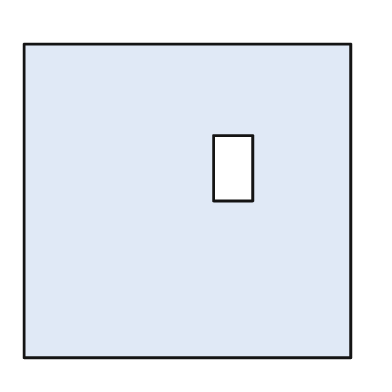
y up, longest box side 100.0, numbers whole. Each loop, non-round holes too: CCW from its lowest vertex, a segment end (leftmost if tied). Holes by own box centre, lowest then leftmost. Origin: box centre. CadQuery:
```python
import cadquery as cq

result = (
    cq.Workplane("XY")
    .moveTo(-50.0, -48.0)
    .lineTo(50.0, -48.0)
    .lineTo(50.0, 48.0)
    .lineTo(-50.0, 48.0)
    .close()
    .moveTo(8.0, 0.0)
    .lineTo(20.0, 0.0)
    .lineTo(20.0, 20.0)
    .lineTo(8.0, 20.0)
    .close()
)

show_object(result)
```